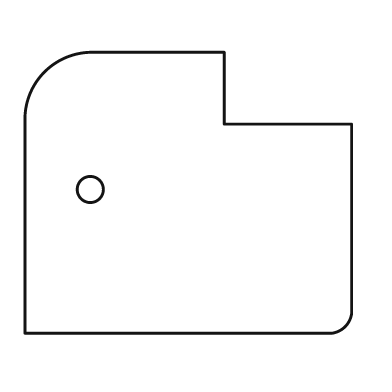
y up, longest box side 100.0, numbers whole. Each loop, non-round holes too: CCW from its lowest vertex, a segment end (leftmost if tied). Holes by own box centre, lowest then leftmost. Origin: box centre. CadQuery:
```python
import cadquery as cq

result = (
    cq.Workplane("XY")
    .moveTo(-50.0, -43.0)
    .lineTo(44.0, -43.0)
    .threePointArc((48.0, -41.0), (50.0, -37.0))
    .lineTo(50.0, 21.0)
    .lineTo(11.0, 21.0)
    .lineTo(11.0, 43.0)
    .lineTo(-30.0, 43.0)
    .threePointArc((-44.0, 37.0), (-50.0, 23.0))
    .close()
    .moveTo(-30.0, 1.0)
    .circle(4.0)
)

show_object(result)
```